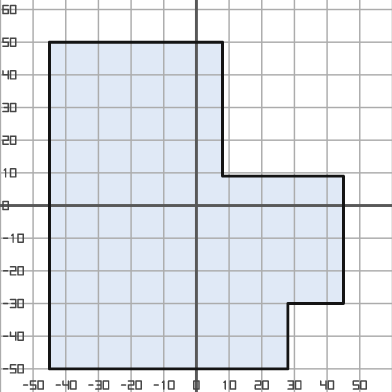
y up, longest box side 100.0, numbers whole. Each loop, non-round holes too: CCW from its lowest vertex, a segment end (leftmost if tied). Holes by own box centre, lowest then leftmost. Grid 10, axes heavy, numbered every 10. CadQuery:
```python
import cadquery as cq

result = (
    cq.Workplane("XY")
    .moveTo(-45.0, -50.0)
    .lineTo(28.0, -50.0)
    .lineTo(28.0, -30.0)
    .lineTo(45.0, -30.0)
    .lineTo(45.0, 9.0)
    .lineTo(8.0, 9.0)
    .lineTo(8.0, 50.0)
    .lineTo(-45.0, 50.0)
    .close()
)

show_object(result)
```